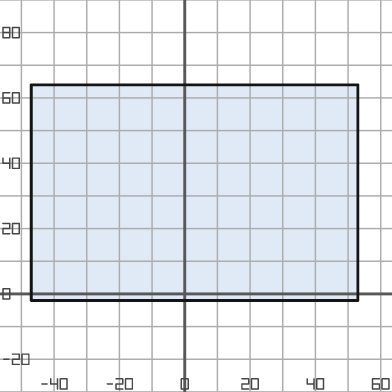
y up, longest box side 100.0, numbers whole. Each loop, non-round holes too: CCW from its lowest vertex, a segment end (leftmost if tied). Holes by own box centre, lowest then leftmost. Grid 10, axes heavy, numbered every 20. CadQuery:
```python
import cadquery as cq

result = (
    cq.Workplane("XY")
    .moveTo(-47.0, -2.0)
    .lineTo(53.0, -2.0)
    .lineTo(53.0, 64.0)
    .lineTo(-47.0, 64.0)
    .close()
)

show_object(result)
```